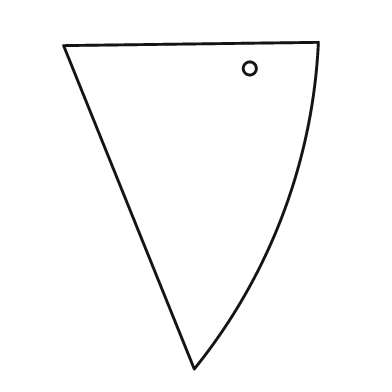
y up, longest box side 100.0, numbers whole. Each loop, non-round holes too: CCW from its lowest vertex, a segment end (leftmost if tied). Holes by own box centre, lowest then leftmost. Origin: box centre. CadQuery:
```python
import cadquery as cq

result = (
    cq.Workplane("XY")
    .moveTo(1.0, -50.0)
    .threePointArc((28.0, -3.0), (39.0, 50.0))
    .lineTo(-39.0, 49.0)
    .close()
    .moveTo(18.0, 42.0)
    .circle(2.0)
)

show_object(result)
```